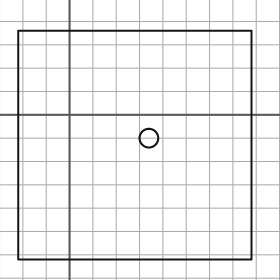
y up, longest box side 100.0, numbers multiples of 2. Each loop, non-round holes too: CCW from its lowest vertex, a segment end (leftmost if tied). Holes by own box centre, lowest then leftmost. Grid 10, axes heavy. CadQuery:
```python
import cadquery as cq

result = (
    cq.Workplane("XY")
    .moveTo(-22.0, -62.0)
    .lineTo(78.0, -62.0)
    .lineTo(78.0, 36.0)
    .lineTo(-22.0, 36.0)
    .close()
    .moveTo(34.0, -10.0)
    .circle(4.0)
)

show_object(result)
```